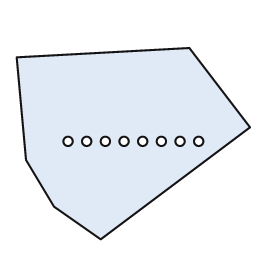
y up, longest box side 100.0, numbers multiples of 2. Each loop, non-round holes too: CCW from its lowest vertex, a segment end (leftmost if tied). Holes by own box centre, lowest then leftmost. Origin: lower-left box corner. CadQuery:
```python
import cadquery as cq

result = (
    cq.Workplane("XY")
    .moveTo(36.0, 0.0)
    .lineTo(100.0, 48.0)
    .lineTo(74.0, 82.0)
    .lineTo(0.0, 78.0)
    .lineTo(4.0, 34.0)
    .lineTo(16.0, 14.0)
    .close()
    .moveTo(22.0, 42.0)
    .circle(2.0)
    .moveTo(30.0, 42.0)
    .circle(2.0)
    .moveTo(38.0, 42.0)
    .circle(2.0)
    .moveTo(46.0, 42.0)
    .circle(2.0)
    .moveTo(54.0, 42.0)
    .circle(2.0)
    .moveTo(62.0, 42.0)
    .circle(2.0)
    .moveTo(70.0, 42.0)
    .circle(2.0)
    .moveTo(78.0, 42.0)
    .circle(2.0)
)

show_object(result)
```